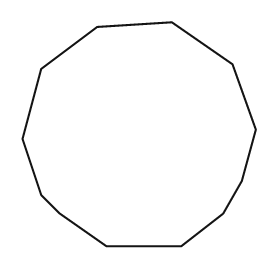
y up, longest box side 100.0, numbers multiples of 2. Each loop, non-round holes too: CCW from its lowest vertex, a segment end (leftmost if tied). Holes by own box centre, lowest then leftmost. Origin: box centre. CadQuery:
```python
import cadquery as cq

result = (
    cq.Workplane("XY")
    .moveTo(-14.0, -48.0)
    .lineTo(18.0, -48.0)
    .lineTo(36.0, -34.0)
    .lineTo(44.0, -20.0)
    .lineTo(50.0, 2.0)
    .lineTo(40.0, 30.0)
    .lineTo(14.0, 48.0)
    .lineTo(-18.0, 46.0)
    .lineTo(-42.0, 28.0)
    .lineTo(-50.0, -2.0)
    .lineTo(-42.0, -26.0)
    .lineTo(-34.0, -34.0)
    .close()
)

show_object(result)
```